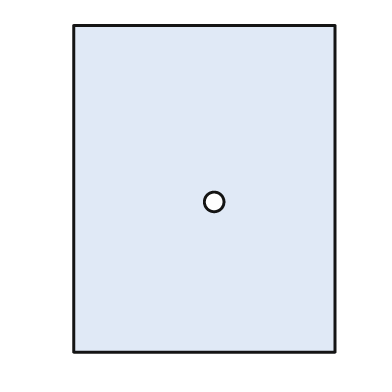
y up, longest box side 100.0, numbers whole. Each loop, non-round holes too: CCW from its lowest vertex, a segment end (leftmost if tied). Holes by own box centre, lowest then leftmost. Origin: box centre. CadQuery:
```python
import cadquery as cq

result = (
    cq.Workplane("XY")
    .moveTo(-40.0, -50.0)
    .lineTo(40.0, -50.0)
    .lineTo(40.0, 50.0)
    .lineTo(-40.0, 50.0)
    .close()
    .moveTo(3.0, -4.0)
    .circle(3.0)
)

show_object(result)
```